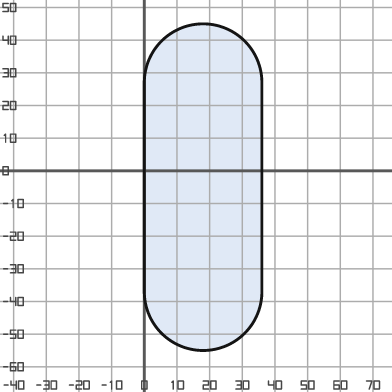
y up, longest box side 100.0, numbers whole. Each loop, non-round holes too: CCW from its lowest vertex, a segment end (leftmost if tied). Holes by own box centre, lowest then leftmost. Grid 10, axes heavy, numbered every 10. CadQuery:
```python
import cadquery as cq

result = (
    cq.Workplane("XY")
    .moveTo(0.0, -37.0)
    .threePointArc((18.0, -55.0), (36.0, -37.0))
    .lineTo(36.0, 27.0)
    .threePointArc((18.0, 45.0), (0.0, 27.0))
    .close()
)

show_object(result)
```